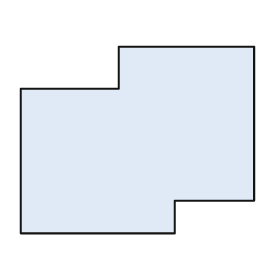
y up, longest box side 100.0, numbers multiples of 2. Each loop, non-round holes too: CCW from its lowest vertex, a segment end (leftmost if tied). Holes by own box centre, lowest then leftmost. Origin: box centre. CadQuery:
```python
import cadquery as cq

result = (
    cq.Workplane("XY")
    .moveTo(-50.0, -40.0)
    .lineTo(16.0, -40.0)
    .lineTo(16.0, -26.0)
    .lineTo(50.0, -26.0)
    .lineTo(50.0, 40.0)
    .lineTo(-8.0, 40.0)
    .lineTo(-8.0, 22.0)
    .lineTo(-50.0, 22.0)
    .close()
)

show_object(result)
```